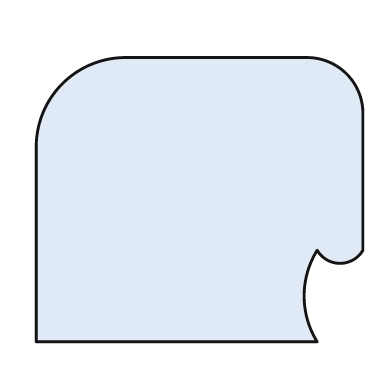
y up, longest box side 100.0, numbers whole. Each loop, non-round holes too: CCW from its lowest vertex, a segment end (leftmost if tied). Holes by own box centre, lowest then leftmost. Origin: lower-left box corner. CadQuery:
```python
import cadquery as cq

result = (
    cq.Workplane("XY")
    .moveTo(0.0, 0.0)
    .lineTo(86.0, 0.0)
    .threePointArc((82.0, 14.0), (86.0, 28.0))
    .threePointArc((93.0, 24.0), (100.0, 28.0))
    .lineTo(100.0, 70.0)
    .threePointArc((95.0, 82.0), (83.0, 87.0))
    .lineTo(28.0, 87.0)
    .threePointArc((8.0, 79.0), (0.0, 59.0))
    .close()
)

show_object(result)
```